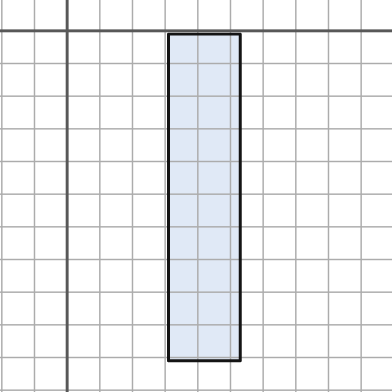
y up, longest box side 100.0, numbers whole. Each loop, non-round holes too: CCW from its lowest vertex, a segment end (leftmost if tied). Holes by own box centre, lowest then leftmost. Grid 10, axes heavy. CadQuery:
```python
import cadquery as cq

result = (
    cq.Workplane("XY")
    .moveTo(31.0, -101.0)
    .lineTo(53.0, -101.0)
    .lineTo(53.0, -1.0)
    .lineTo(31.0, -1.0)
    .close()
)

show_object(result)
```